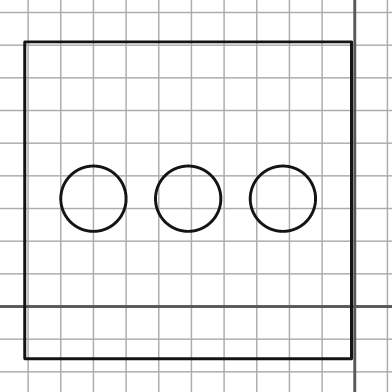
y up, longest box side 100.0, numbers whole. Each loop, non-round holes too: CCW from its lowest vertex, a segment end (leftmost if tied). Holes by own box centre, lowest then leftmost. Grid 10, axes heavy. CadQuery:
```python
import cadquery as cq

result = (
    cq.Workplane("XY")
    .moveTo(-101.0, -16.0)
    .lineTo(-1.0, -16.0)
    .lineTo(-1.0, 81.0)
    .lineTo(-101.0, 81.0)
    .close()
    .moveTo(-80.0, 33.0)
    .circle(10.0)
    .moveTo(-51.0, 33.0)
    .circle(10.0)
    .moveTo(-22.0, 33.0)
    .circle(10.0)
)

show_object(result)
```